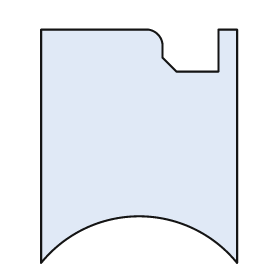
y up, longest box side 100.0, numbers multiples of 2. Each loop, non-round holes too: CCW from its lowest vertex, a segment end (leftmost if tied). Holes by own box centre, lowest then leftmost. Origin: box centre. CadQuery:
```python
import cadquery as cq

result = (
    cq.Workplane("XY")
    .moveTo(-42.0, -50.0)
    .threePointArc((0.0, -30.0), (42.0, -50.0))
    .lineTo(42.0, 50.0)
    .lineTo(34.0, 50.0)
    .lineTo(34.0, 32.0)
    .lineTo(16.0, 32.0)
    .lineTo(10.0, 38.0)
    .lineTo(10.0, 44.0)
    .threePointArc((8.0, 48.0), (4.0, 50.0))
    .lineTo(-42.0, 50.0)
    .close()
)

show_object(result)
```